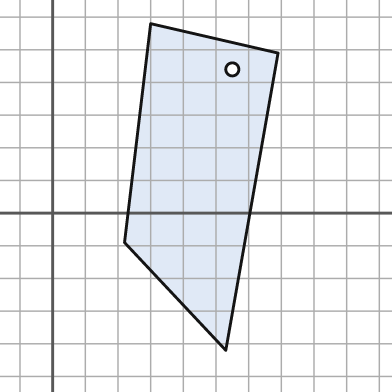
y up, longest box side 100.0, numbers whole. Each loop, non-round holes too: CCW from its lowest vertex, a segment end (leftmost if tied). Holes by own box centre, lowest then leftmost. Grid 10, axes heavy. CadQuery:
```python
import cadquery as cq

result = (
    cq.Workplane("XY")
    .moveTo(53.0, -42.0)
    .lineTo(69.0, 49.0)
    .lineTo(30.0, 58.0)
    .lineTo(22.0, -9.0)
    .close()
    .moveTo(55.0, 44.0)
    .circle(2.0)
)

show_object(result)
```